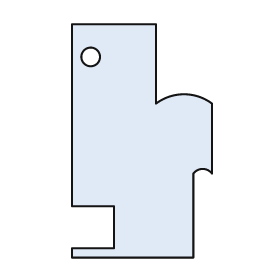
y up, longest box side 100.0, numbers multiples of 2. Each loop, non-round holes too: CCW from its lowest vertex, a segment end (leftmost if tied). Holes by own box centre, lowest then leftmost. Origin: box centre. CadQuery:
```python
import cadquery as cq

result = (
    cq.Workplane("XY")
    .moveTo(-30.0, -50.0)
    .lineTo(22.0, -50.0)
    .lineTo(22.0, -14.0)
    .threePointArc((26.0, -12.0), (30.0, -14.0))
    .lineTo(30.0, 16.0)
    .threePointArc((18.0, 20.0), (6.0, 16.0))
    .lineTo(6.0, 50.0)
    .lineTo(-30.0, 50.0)
    .lineTo(-30.0, -28.0)
    .lineTo(-12.0, -28.0)
    .lineTo(-12.0, -46.0)
    .lineTo(-30.0, -46.0)
    .close()
    .moveTo(-22.0, 36.0)
    .circle(4.0)
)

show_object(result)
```